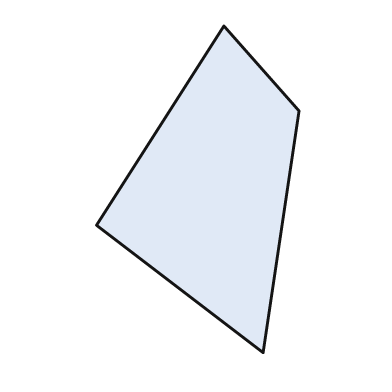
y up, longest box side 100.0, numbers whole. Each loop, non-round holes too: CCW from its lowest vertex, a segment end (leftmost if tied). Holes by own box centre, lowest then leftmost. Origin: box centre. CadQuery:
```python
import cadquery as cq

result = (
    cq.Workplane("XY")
    .moveTo(20.0, -50.0)
    .lineTo(31.0, 24.0)
    .lineTo(8.0, 50.0)
    .lineTo(-31.0, -11.0)
    .close()
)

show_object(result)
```